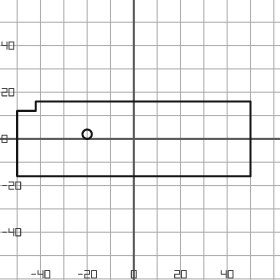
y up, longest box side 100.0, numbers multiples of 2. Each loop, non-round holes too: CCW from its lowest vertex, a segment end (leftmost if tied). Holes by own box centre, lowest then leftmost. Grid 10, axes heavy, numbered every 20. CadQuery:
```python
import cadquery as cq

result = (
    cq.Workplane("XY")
    .moveTo(-50.0, -16.0)
    .lineTo(50.0, -16.0)
    .lineTo(50.0, 16.0)
    .lineTo(-42.0, 16.0)
    .lineTo(-42.0, 12.0)
    .lineTo(-50.0, 12.0)
    .close()
    .moveTo(-20.0, 2.0)
    .circle(2.0)
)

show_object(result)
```